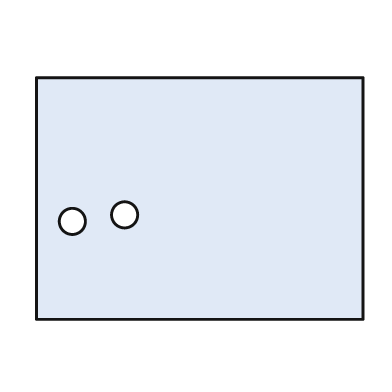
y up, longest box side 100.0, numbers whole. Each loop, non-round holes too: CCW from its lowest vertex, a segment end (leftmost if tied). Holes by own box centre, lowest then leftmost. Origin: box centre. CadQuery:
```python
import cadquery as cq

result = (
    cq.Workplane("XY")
    .moveTo(-50.0, -37.0)
    .lineTo(50.0, -37.0)
    .lineTo(50.0, 37.0)
    .lineTo(-50.0, 37.0)
    .close()
    .moveTo(-39.0, -7.0)
    .circle(4.0)
    .moveTo(-23.0, -5.0)
    .circle(4.0)
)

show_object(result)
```